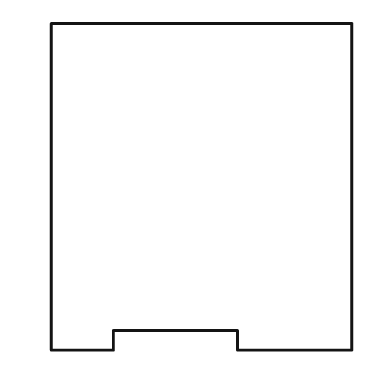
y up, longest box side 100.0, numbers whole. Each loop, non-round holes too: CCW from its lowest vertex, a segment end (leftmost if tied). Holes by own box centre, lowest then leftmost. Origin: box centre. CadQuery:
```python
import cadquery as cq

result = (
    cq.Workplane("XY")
    .moveTo(-46.0, -50.0)
    .lineTo(-27.0, -50.0)
    .lineTo(-27.0, -44.0)
    .lineTo(11.0, -44.0)
    .lineTo(11.0, -50.0)
    .lineTo(46.0, -50.0)
    .lineTo(46.0, 50.0)
    .lineTo(-46.0, 50.0)
    .close()
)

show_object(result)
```